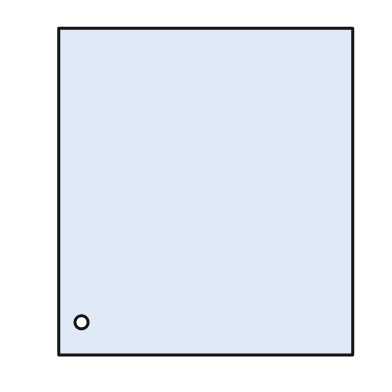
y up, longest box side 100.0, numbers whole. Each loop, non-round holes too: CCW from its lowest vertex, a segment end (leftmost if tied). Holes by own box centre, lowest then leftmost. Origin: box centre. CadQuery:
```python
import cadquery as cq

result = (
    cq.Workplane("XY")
    .moveTo(-45.0, -50.0)
    .lineTo(45.0, -50.0)
    .lineTo(45.0, 50.0)
    .lineTo(-45.0, 50.0)
    .close()
    .moveTo(-38.0, -40.0)
    .circle(2.0)
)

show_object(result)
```